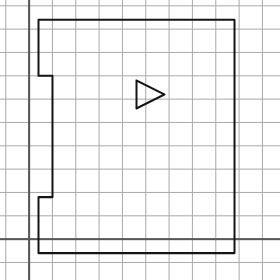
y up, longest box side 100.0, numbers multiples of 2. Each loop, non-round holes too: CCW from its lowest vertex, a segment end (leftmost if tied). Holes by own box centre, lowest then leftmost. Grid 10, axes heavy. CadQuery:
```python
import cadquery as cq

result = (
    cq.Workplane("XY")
    .moveTo(4.0, -6.0)
    .lineTo(88.0, -6.0)
    .lineTo(88.0, 94.0)
    .lineTo(4.0, 94.0)
    .lineTo(4.0, 70.0)
    .lineTo(10.0, 70.0)
    .lineTo(10.0, 18.0)
    .lineTo(4.0, 18.0)
    .close()
    .moveTo(46.0, 56.0)
    .lineTo(58.0, 62.0)
    .lineTo(46.0, 68.0)
    .close()
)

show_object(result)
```